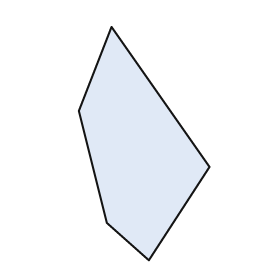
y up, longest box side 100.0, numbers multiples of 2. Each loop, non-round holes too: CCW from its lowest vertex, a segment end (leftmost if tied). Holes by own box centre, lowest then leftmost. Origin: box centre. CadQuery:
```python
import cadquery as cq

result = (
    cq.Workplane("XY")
    .moveTo(2.0, -50.0)
    .lineTo(28.0, -10.0)
    .lineTo(-14.0, 50.0)
    .lineTo(-28.0, 14.0)
    .lineTo(-16.0, -34.0)
    .close()
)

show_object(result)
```